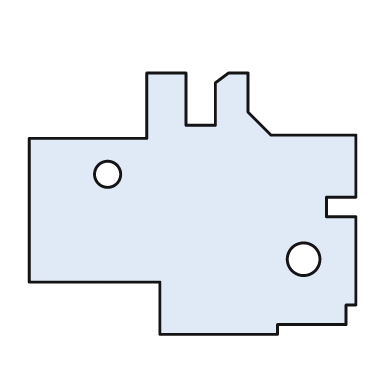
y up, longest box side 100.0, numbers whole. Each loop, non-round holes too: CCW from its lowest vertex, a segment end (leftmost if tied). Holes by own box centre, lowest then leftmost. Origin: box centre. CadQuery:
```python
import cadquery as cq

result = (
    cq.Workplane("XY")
    .moveTo(-10.0, -40.0)
    .lineTo(26.0, -40.0)
    .lineTo(26.0, -37.0)
    .lineTo(47.0, -37.0)
    .lineTo(47.0, -31.0)
    .lineTo(50.0, -31.0)
    .lineTo(50.0, -4.0)
    .lineTo(41.0, -4.0)
    .lineTo(41.0, 2.0)
    .lineTo(50.0, 2.0)
    .lineTo(50.0, 21.0)
    .lineTo(24.0, 21.0)
    .lineTo(17.0, 28.0)
    .lineTo(17.0, 40.0)
    .lineTo(11.0, 40.0)
    .lineTo(7.0, 37.0)
    .lineTo(7.0, 24.0)
    .lineTo(-2.0, 24.0)
    .lineTo(-2.0, 40.0)
    .lineTo(-14.0, 40.0)
    .lineTo(-14.0, 20.0)
    .lineTo(-50.0, 20.0)
    .lineTo(-50.0, -24.0)
    .lineTo(-10.0, -24.0)
    .close()
    .moveTo(34.0, -17.0)
    .circle(5.0)
    .moveTo(-26.0, 9.0)
    .circle(4.0)
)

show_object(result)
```